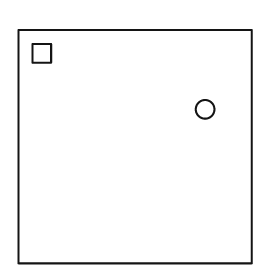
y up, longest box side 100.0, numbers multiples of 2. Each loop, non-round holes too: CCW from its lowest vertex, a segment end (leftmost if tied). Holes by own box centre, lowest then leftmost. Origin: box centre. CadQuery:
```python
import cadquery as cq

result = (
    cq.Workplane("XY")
    .moveTo(-50.0, -50.0)
    .lineTo(50.0, -50.0)
    .lineTo(50.0, 50.0)
    .lineTo(-50.0, 50.0)
    .close()
    .moveTo(30.0, 16.0)
    .circle(4.0)
    .moveTo(-44.0, 36.0)
    .lineTo(-36.0, 36.0)
    .lineTo(-36.0, 44.0)
    .lineTo(-44.0, 44.0)
    .close()
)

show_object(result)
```